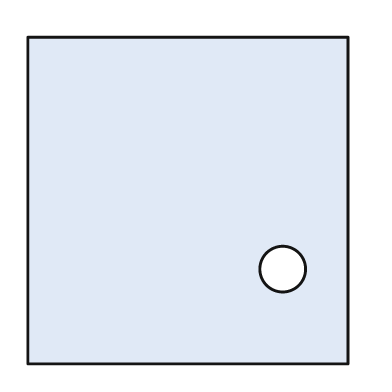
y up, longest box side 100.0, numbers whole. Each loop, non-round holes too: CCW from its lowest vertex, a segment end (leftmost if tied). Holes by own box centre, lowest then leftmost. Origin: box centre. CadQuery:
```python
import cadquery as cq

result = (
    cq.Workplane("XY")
    .moveTo(-49.0, -50.0)
    .lineTo(49.0, -50.0)
    .lineTo(49.0, 50.0)
    .lineTo(-49.0, 50.0)
    .close()
    .moveTo(29.0, -21.0)
    .circle(7.0)
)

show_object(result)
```